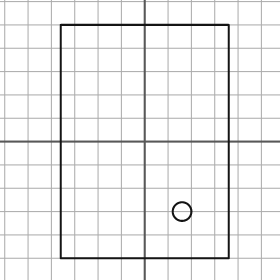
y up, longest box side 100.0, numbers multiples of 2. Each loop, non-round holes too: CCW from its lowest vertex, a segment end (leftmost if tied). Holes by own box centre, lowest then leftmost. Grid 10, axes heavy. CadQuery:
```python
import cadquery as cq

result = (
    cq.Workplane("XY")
    .moveTo(-36.0, -50.0)
    .lineTo(36.0, -50.0)
    .lineTo(36.0, 50.0)
    .lineTo(-36.0, 50.0)
    .close()
    .moveTo(16.0, -30.0)
    .circle(4.0)
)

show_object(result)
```